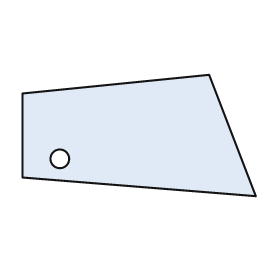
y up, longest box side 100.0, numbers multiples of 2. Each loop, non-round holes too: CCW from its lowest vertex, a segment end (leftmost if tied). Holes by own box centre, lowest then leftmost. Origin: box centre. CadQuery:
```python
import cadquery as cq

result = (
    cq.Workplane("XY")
    .moveTo(50.0, -26.0)
    .lineTo(30.0, 26.0)
    .lineTo(-50.0, 18.0)
    .lineTo(-50.0, -18.0)
    .close()
    .moveTo(-34.0, -10.0)
    .circle(4.0)
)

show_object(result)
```